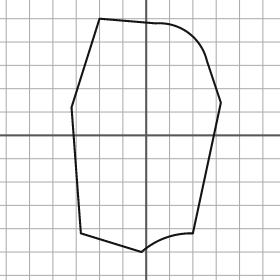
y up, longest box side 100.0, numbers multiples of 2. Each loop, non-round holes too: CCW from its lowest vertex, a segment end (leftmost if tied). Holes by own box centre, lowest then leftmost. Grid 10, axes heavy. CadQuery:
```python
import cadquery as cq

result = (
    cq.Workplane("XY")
    .moveTo(-2.0, -50.0)
    .threePointArc((8.0, -44.0), (20.0, -42.0))
    .lineTo(32.0, 14.0)
    .lineTo(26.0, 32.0)
    .threePointArc((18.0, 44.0), (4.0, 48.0))
    .lineTo(-20.0, 50.0)
    .lineTo(-32.0, 12.0)
    .lineTo(-28.0, -42.0)
    .close()
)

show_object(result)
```